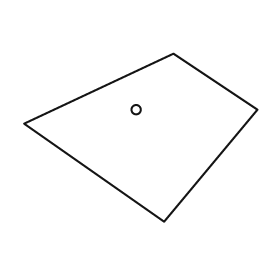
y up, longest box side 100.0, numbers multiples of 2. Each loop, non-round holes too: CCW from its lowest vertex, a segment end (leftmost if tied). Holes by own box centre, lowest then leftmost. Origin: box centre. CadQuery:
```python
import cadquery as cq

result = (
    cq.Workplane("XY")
    .moveTo(10.0, -36.0)
    .lineTo(50.0, 12.0)
    .lineTo(14.0, 36.0)
    .lineTo(-50.0, 6.0)
    .close()
    .moveTo(-2.0, 12.0)
    .circle(2.0)
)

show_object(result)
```